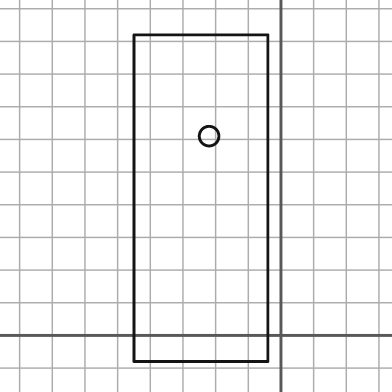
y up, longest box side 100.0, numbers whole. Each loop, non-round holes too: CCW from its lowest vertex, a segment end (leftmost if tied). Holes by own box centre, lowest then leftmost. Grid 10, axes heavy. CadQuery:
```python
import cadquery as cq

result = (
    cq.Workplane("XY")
    .moveTo(-45.0, -8.0)
    .lineTo(-4.0, -8.0)
    .lineTo(-4.0, 92.0)
    .lineTo(-45.0, 92.0)
    .close()
    .moveTo(-22.0, 61.0)
    .circle(3.0)
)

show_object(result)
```